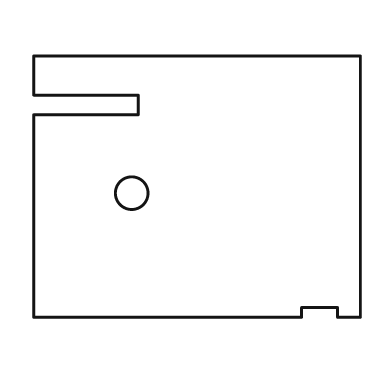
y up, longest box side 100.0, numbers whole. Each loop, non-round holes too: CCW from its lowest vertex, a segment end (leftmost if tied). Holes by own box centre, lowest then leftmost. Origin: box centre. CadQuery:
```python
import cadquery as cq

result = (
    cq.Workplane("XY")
    .moveTo(-50.0, -40.0)
    .lineTo(32.0, -40.0)
    .lineTo(32.0, -37.0)
    .lineTo(43.0, -37.0)
    .lineTo(43.0, -40.0)
    .lineTo(50.0, -40.0)
    .lineTo(50.0, 40.0)
    .lineTo(-50.0, 40.0)
    .lineTo(-50.0, 28.0)
    .lineTo(-18.0, 28.0)
    .lineTo(-18.0, 22.0)
    .lineTo(-50.0, 22.0)
    .close()
    .moveTo(-20.0, -2.0)
    .circle(5.0)
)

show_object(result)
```